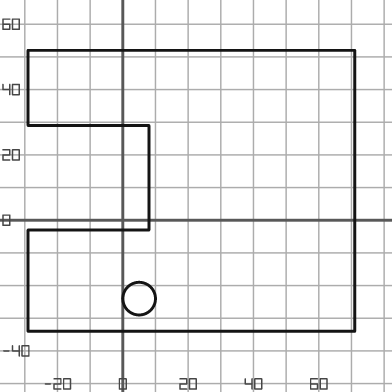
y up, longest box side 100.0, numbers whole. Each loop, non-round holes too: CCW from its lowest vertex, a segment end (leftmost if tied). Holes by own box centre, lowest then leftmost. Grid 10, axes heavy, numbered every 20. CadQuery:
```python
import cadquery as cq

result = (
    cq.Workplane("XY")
    .moveTo(-29.0, -34.0)
    .lineTo(71.0, -34.0)
    .lineTo(71.0, 52.0)
    .lineTo(-29.0, 52.0)
    .lineTo(-29.0, 29.0)
    .lineTo(8.0, 29.0)
    .lineTo(8.0, -3.0)
    .lineTo(-29.0, -3.0)
    .close()
    .moveTo(5.0, -24.0)
    .circle(5.0)
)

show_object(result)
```